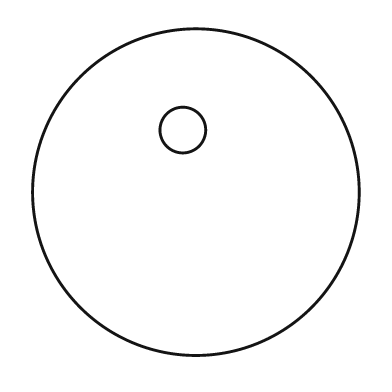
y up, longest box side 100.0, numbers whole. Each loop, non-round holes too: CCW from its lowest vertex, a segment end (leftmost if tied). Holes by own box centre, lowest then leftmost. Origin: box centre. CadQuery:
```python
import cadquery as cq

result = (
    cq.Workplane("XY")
    .moveTo(0.0, 0.0)
    .circle(50.0)
    .moveTo(-4.0, 19.0)
    .circle(7.0)
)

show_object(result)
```